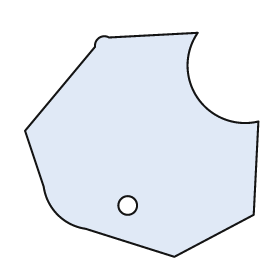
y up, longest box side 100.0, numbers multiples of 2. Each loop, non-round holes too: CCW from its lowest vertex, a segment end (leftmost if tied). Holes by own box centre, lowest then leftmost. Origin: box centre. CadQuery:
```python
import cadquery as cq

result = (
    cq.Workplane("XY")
    .moveTo(14.0, -48.0)
    .lineTo(48.0, -30.0)
    .lineTo(50.0, 10.0)
    .threePointArc((24.0, 20.0), (24.0, 48.0))
    .lineTo(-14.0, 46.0)
    .threePointArc((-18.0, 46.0), (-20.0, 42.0))
    .lineTo(-50.0, 6.0)
    .lineTo(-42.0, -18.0)
    .threePointArc((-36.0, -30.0), (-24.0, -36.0))
    .close()
    .moveTo(-6.0, -26.0)
    .circle(4.0)
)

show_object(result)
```